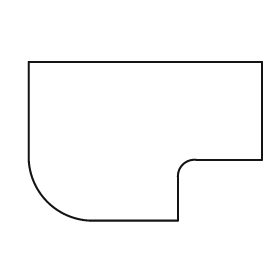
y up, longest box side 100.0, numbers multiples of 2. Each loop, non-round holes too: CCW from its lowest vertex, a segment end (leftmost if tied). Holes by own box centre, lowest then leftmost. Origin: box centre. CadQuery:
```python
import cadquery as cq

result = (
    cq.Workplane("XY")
    .moveTo(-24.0, -34.0)
    .lineTo(14.0, -34.0)
    .lineTo(14.0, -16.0)
    .threePointArc((16.0, -10.0), (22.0, -8.0))
    .lineTo(50.0, -8.0)
    .lineTo(50.0, 34.0)
    .lineTo(-50.0, 34.0)
    .lineTo(-50.0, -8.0)
    .threePointArc((-42.0, -26.0), (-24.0, -34.0))
    .close()
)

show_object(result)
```